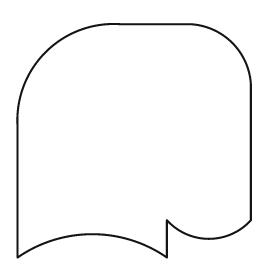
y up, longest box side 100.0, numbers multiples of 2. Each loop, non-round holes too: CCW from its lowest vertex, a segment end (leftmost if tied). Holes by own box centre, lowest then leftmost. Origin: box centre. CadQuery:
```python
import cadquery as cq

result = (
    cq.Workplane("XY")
    .moveTo(-50.0, -50.0)
    .threePointArc((-18.0, -40.0), (14.0, -50.0))
    .lineTo(14.0, -34.0)
    .threePointArc((32.0, -42.0), (50.0, -34.0))
    .lineTo(50.0, 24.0)
    .threePointArc((42.0, 42.0), (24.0, 50.0))
    .lineTo(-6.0, 50.0)
    .threePointArc((-38.0, 38.0), (-50.0, 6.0))
    .close()
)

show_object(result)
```